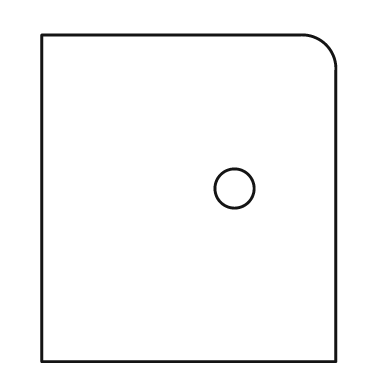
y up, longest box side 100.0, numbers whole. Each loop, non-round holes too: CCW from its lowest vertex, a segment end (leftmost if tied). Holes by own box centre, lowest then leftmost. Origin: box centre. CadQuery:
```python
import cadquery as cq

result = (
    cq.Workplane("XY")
    .moveTo(-45.0, -50.0)
    .lineTo(45.0, -50.0)
    .lineTo(45.0, 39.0)
    .threePointArc((42.0, 47.0), (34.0, 50.0))
    .lineTo(-45.0, 50.0)
    .close()
    .moveTo(14.0, 3.0)
    .circle(6.0)
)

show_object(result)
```